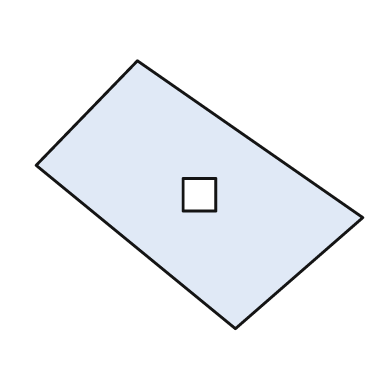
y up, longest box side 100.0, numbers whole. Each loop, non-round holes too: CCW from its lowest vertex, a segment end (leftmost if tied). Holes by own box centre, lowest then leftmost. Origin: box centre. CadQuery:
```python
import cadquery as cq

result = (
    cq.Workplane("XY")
    .moveTo(11.0, -41.0)
    .lineTo(50.0, -7.0)
    .lineTo(-19.0, 41.0)
    .lineTo(-50.0, 9.0)
    .close()
    .moveTo(-5.0, -5.0)
    .lineTo(5.0, -5.0)
    .lineTo(5.0, 5.0)
    .lineTo(-5.0, 5.0)
    .close()
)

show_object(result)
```